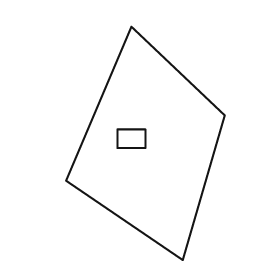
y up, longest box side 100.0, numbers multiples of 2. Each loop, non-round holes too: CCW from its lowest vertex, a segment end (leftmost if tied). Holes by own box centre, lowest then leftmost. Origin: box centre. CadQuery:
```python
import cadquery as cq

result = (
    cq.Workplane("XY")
    .moveTo(16.0, -50.0)
    .lineTo(34.0, 12.0)
    .lineTo(-6.0, 50.0)
    .lineTo(-34.0, -16.0)
    .close()
    .moveTo(-12.0, -2.0)
    .lineTo(0.0, -2.0)
    .lineTo(0.0, 6.0)
    .lineTo(-12.0, 6.0)
    .close()
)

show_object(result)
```